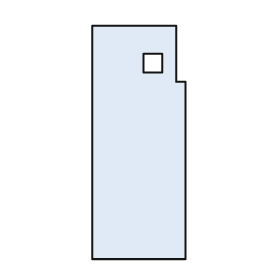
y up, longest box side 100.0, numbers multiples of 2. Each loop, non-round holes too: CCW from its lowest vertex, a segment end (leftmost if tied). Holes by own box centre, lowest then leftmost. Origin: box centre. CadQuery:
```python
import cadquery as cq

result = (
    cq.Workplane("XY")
    .moveTo(-20.0, -50.0)
    .lineTo(20.0, -50.0)
    .lineTo(20.0, 26.0)
    .lineTo(16.0, 26.0)
    .lineTo(16.0, 50.0)
    .lineTo(-20.0, 50.0)
    .close()
    .moveTo(2.0, 30.0)
    .lineTo(10.0, 30.0)
    .lineTo(10.0, 38.0)
    .lineTo(2.0, 38.0)
    .close()
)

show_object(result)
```